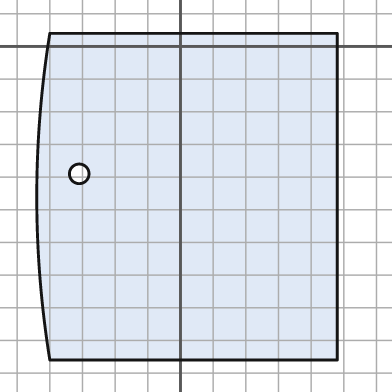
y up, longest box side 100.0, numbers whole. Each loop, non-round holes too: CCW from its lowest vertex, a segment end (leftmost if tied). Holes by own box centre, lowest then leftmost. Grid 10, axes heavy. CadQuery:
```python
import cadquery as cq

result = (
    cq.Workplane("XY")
    .moveTo(-40.0, -96.0)
    .lineTo(48.0, -96.0)
    .lineTo(48.0, 4.0)
    .lineTo(-40.0, 4.0)
    .threePointArc((-44.0, -46.0), (-40.0, -96.0))
    .close()
    .moveTo(-31.0, -39.0)
    .circle(3.0)
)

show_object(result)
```